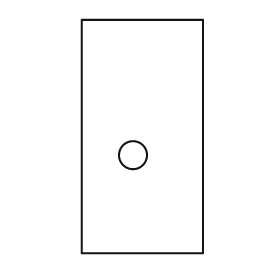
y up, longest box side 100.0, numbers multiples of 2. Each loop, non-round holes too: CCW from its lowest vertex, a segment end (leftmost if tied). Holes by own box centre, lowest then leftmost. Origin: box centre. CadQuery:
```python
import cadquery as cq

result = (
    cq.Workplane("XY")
    .moveTo(-26.0, -50.0)
    .lineTo(26.0, -50.0)
    .lineTo(26.0, 50.0)
    .lineTo(-26.0, 50.0)
    .close()
    .moveTo(-4.0, -8.0)
    .circle(6.0)
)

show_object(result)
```